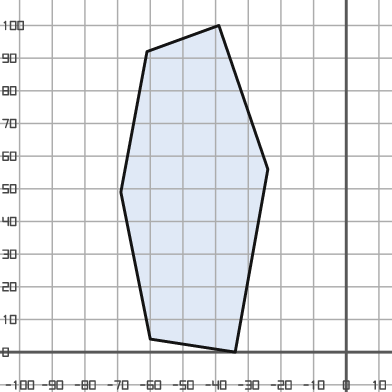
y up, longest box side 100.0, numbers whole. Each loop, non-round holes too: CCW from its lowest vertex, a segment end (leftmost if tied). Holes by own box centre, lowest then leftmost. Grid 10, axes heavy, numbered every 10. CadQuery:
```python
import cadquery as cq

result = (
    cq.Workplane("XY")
    .moveTo(-34.0, 0.0)
    .lineTo(-24.0, 56.0)
    .lineTo(-39.0, 100.0)
    .lineTo(-61.0, 92.0)
    .lineTo(-69.0, 49.0)
    .lineTo(-60.0, 4.0)
    .close()
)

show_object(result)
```